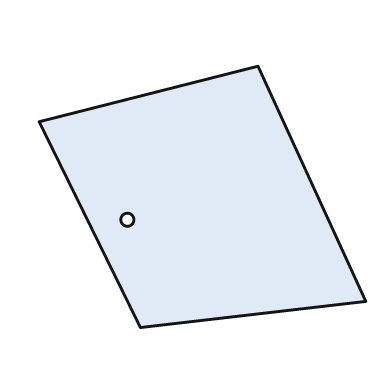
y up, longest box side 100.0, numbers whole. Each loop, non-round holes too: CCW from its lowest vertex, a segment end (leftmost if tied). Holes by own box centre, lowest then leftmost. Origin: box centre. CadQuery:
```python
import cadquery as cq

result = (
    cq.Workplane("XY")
    .moveTo(-19.0, -40.0)
    .lineTo(50.0, -32.0)
    .lineTo(17.0, 40.0)
    .lineTo(-50.0, 23.0)
    .close()
    .moveTo(-23.0, -7.0)
    .circle(2.0)
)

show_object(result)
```